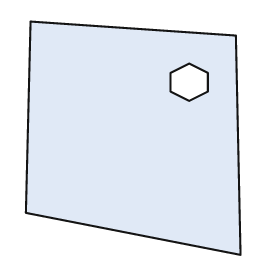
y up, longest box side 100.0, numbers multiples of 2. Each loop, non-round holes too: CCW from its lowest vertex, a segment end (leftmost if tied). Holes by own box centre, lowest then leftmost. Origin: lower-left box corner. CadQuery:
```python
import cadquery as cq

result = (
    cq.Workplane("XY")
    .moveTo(92.0, 0.0)
    .lineTo(90.0, 94.0)
    .lineTo(2.0, 100.0)
    .lineTo(0.0, 18.0)
    .close()
    .moveTo(70.0, 66.0)
    .lineTo(78.0, 70.0)
    .lineTo(78.0, 78.0)
    .lineTo(70.0, 82.0)
    .lineTo(62.0, 78.0)
    .lineTo(62.0, 70.0)
    .close()
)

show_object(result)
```